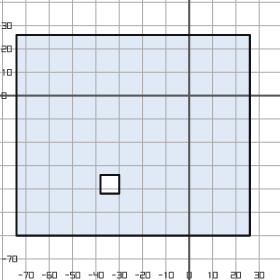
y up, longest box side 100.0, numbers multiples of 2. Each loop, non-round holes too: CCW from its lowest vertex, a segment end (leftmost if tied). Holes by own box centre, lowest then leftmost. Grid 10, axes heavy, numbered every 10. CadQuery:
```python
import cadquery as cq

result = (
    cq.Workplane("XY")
    .moveTo(-74.0, -60.0)
    .lineTo(26.0, -60.0)
    .lineTo(26.0, 26.0)
    .lineTo(-74.0, 26.0)
    .close()
    .moveTo(-38.0, -42.0)
    .lineTo(-30.0, -42.0)
    .lineTo(-30.0, -34.0)
    .lineTo(-38.0, -34.0)
    .close()
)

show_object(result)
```